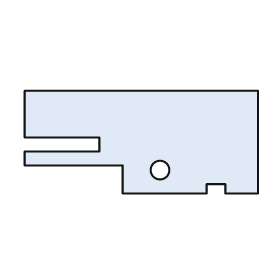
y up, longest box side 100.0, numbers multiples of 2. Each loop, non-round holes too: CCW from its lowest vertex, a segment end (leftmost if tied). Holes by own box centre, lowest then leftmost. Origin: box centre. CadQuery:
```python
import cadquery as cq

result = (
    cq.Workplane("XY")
    .moveTo(-8.0, -22.0)
    .lineTo(28.0, -22.0)
    .lineTo(28.0, -18.0)
    .lineTo(36.0, -18.0)
    .lineTo(36.0, -22.0)
    .lineTo(50.0, -22.0)
    .lineTo(50.0, 22.0)
    .lineTo(-50.0, 22.0)
    .lineTo(-50.0, 2.0)
    .lineTo(-18.0, 2.0)
    .lineTo(-18.0, -4.0)
    .lineTo(-50.0, -4.0)
    .lineTo(-50.0, -10.0)
    .lineTo(-8.0, -10.0)
    .close()
    .moveTo(8.0, -12.0)
    .circle(4.0)
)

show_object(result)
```